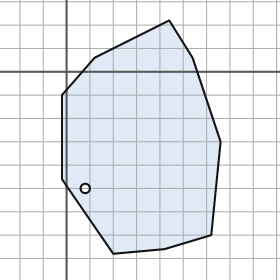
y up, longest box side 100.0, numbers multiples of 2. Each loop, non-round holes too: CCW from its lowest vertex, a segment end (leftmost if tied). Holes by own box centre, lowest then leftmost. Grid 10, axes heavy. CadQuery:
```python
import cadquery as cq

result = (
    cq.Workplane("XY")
    .moveTo(20.0, -78.0)
    .lineTo(42.0, -76.0)
    .lineTo(62.0, -70.0)
    .lineTo(66.0, -30.0)
    .lineTo(54.0, 6.0)
    .lineTo(44.0, 22.0)
    .lineTo(12.0, 6.0)
    .lineTo(-2.0, -10.0)
    .lineTo(-2.0, -46.0)
    .close()
    .moveTo(8.0, -50.0)
    .circle(2.0)
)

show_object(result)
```